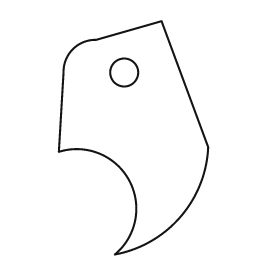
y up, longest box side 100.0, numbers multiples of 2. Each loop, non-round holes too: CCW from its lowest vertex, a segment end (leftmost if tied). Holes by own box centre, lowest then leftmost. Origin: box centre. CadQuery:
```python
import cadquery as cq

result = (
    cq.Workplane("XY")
    .moveTo(-8.0, -50.0)
    .threePointArc((20.0, -34.0), (32.0, -4.0))
    .lineTo(12.0, 50.0)
    .lineTo(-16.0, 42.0)
    .threePointArc((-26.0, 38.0), (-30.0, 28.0))
    .lineTo(-32.0, -6.0)
    .threePointArc((-2.0, -18.0), (-8.0, -50.0))
    .close()
    .moveTo(-4.0, 28.0)
    .circle(6.0)
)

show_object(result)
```